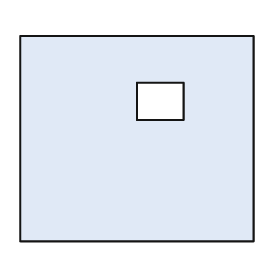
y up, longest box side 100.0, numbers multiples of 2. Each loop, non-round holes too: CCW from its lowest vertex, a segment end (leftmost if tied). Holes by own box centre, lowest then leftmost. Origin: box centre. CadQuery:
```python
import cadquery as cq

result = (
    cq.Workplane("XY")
    .moveTo(-50.0, -44.0)
    .lineTo(50.0, -44.0)
    .lineTo(50.0, 44.0)
    .lineTo(-50.0, 44.0)
    .close()
    .moveTo(0.0, 8.0)
    .lineTo(20.0, 8.0)
    .lineTo(20.0, 24.0)
    .lineTo(0.0, 24.0)
    .close()
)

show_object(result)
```